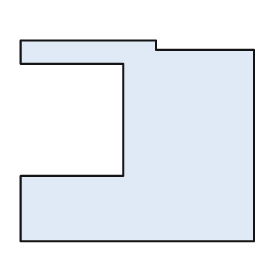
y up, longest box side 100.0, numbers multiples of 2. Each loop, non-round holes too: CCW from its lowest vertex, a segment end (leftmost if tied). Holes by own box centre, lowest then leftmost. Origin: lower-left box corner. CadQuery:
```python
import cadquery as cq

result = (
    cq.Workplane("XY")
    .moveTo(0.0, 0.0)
    .lineTo(100.0, 0.0)
    .lineTo(100.0, 82.0)
    .lineTo(58.0, 82.0)
    .lineTo(58.0, 86.0)
    .lineTo(0.0, 86.0)
    .lineTo(0.0, 76.0)
    .lineTo(44.0, 76.0)
    .lineTo(44.0, 28.0)
    .lineTo(0.0, 28.0)
    .close()
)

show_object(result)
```